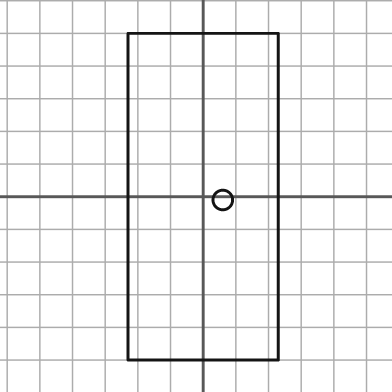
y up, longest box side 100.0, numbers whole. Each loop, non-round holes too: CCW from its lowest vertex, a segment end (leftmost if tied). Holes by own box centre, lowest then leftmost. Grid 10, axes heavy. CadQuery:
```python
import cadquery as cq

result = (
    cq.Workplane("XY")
    .moveTo(-23.0, -50.0)
    .lineTo(23.0, -50.0)
    .lineTo(23.0, 50.0)
    .lineTo(-23.0, 50.0)
    .close()
    .moveTo(6.0, -1.0)
    .circle(3.0)
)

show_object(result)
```